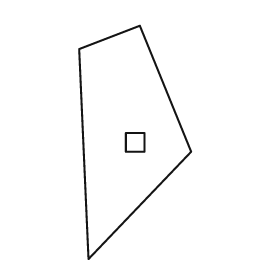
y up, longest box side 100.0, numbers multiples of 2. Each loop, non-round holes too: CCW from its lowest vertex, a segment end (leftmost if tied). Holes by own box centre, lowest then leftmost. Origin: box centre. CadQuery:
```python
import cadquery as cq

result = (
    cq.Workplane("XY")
    .moveTo(-20.0, -50.0)
    .lineTo(24.0, -4.0)
    .lineTo(2.0, 50.0)
    .lineTo(-24.0, 40.0)
    .close()
    .moveTo(-4.0, -4.0)
    .lineTo(4.0, -4.0)
    .lineTo(4.0, 4.0)
    .lineTo(-4.0, 4.0)
    .close()
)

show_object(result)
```